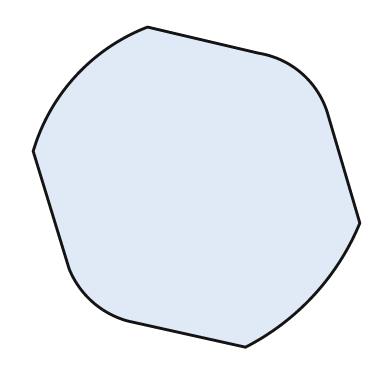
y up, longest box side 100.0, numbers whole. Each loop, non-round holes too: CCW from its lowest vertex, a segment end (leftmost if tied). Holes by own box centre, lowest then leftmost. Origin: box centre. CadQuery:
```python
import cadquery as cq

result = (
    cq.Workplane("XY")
    .moveTo(15.0, -49.0)
    .threePointArc((36.0, -33.0), (50.0, -11.0))
    .lineTo(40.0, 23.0)
    .threePointArc((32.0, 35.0), (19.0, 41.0))
    .lineTo(-15.0, 49.0)
    .threePointArc((-37.0, 34.0), (-50.0, 11.0))
    .lineTo(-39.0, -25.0)
    .threePointArc((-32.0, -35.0), (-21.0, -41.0))
    .close()
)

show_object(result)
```